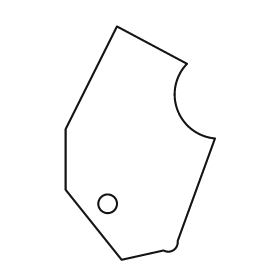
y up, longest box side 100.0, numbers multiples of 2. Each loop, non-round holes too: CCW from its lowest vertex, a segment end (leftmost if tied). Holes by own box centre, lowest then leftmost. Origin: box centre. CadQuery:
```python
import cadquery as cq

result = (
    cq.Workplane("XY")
    .moveTo(-8.0, -50.0)
    .lineTo(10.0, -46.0)
    .threePointArc((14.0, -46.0), (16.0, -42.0))
    .lineTo(32.0, 2.0)
    .threePointArc((16.0, 14.0), (20.0, 34.0))
    .lineTo(-10.0, 50.0)
    .lineTo(-32.0, 6.0)
    .lineTo(-32.0, -20.0)
    .close()
    .moveTo(-14.0, -26.0)
    .circle(4.0)
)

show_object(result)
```